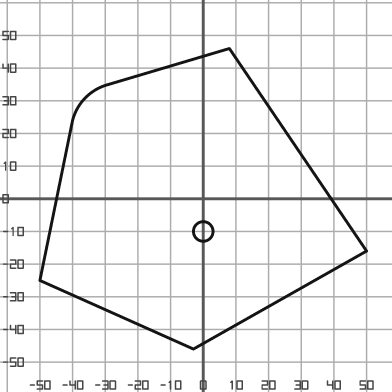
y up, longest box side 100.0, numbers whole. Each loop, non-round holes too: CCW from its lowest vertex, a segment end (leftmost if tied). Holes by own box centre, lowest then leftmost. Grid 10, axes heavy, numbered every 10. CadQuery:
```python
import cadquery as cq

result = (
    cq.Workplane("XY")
    .moveTo(-3.0, -46.0)
    .lineTo(50.0, -16.0)
    .lineTo(8.0, 46.0)
    .lineTo(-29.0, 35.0)
    .threePointArc((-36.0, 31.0), (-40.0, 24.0))
    .lineTo(-50.0, -25.0)
    .close()
    .moveTo(0.0, -10.0)
    .circle(3.0)
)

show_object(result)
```